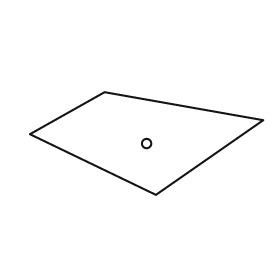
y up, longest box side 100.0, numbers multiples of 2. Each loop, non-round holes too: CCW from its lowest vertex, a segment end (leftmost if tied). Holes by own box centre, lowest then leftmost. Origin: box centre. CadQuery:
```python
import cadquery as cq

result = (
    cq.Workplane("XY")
    .moveTo(4.0, -22.0)
    .lineTo(50.0, 10.0)
    .lineTo(-18.0, 22.0)
    .lineTo(-50.0, 4.0)
    .close()
    .moveTo(0.0, 0.0)
    .circle(2.0)
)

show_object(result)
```